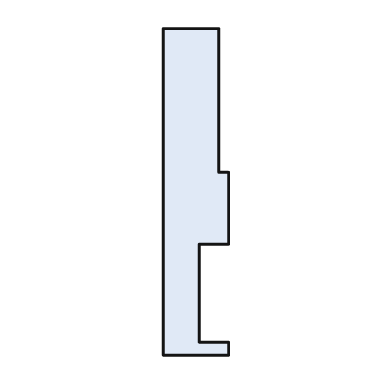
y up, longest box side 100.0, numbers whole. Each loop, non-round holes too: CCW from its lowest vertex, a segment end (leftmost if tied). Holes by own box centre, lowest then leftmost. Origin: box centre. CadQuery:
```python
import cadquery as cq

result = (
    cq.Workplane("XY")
    .moveTo(-10.0, -50.0)
    .lineTo(10.0, -50.0)
    .lineTo(10.0, -46.0)
    .lineTo(1.0, -46.0)
    .lineTo(1.0, -16.0)
    .lineTo(10.0, -16.0)
    .lineTo(10.0, 6.0)
    .lineTo(7.0, 6.0)
    .lineTo(7.0, 50.0)
    .lineTo(-10.0, 50.0)
    .close()
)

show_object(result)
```